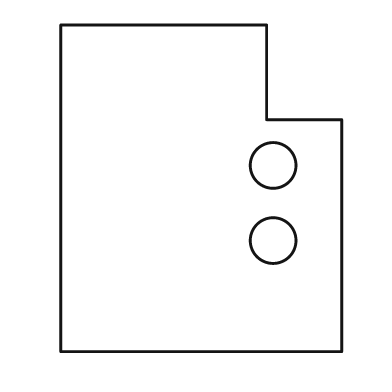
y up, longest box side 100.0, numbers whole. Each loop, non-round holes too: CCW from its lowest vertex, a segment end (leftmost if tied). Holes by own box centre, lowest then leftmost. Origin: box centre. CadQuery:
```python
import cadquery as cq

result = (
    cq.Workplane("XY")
    .moveTo(-43.0, -50.0)
    .lineTo(43.0, -50.0)
    .lineTo(43.0, 21.0)
    .lineTo(20.0, 21.0)
    .lineTo(20.0, 50.0)
    .lineTo(-43.0, 50.0)
    .close()
    .moveTo(22.0, -16.0)
    .circle(7.0)
    .moveTo(22.0, 7.0)
    .circle(7.0)
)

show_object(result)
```